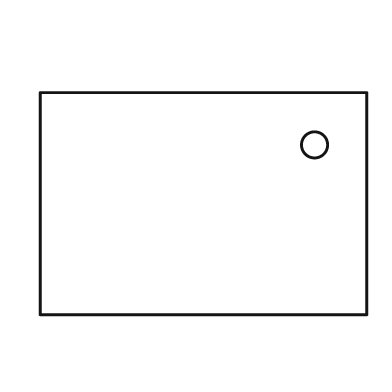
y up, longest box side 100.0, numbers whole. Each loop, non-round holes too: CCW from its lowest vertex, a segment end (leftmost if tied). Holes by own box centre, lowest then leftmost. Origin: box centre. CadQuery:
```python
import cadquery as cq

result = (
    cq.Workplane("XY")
    .moveTo(-50.0, -34.0)
    .lineTo(50.0, -34.0)
    .lineTo(50.0, 34.0)
    .lineTo(-50.0, 34.0)
    .close()
    .moveTo(34.0, 18.0)
    .circle(4.0)
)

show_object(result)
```